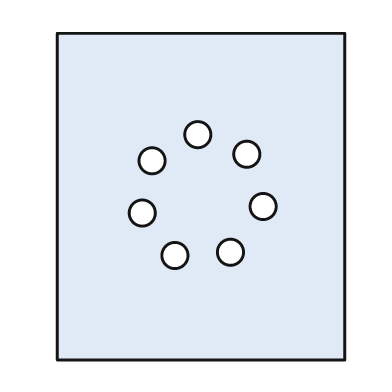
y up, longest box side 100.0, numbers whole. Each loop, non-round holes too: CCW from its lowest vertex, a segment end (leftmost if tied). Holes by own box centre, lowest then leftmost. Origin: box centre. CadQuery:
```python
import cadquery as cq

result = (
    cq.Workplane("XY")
    .moveTo(-44.0, -50.0)
    .lineTo(44.0, -50.0)
    .lineTo(44.0, 50.0)
    .lineTo(-44.0, 50.0)
    .close()
    .moveTo(-8.0, -18.0)
    .circle(4.0)
    .moveTo(9.0, -17.0)
    .circle(4.0)
    .moveTo(-18.0, -5.0)
    .circle(4.0)
    .moveTo(19.0, -3.0)
    .circle(4.0)
    .moveTo(-15.0, 11.0)
    .circle(4.0)
    .moveTo(14.0, 13.0)
    .circle(4.0)
    .moveTo(-1.0, 19.0)
    .circle(4.0)
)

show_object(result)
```